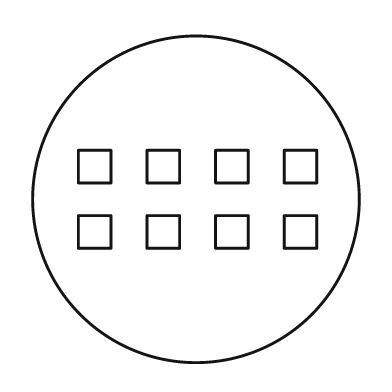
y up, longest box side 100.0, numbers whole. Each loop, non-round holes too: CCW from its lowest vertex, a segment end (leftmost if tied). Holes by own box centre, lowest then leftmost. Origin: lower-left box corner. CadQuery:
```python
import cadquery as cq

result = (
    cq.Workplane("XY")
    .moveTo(50.0, 50.0)
    .circle(50.0)
    .moveTo(14.0, 35.0)
    .lineTo(24.0, 35.0)
    .lineTo(24.0, 45.0)
    .lineTo(14.0, 45.0)
    .close()
    .moveTo(35.0, 35.0)
    .lineTo(45.0, 35.0)
    .lineTo(45.0, 45.0)
    .lineTo(35.0, 45.0)
    .close()
    .moveTo(56.0, 35.0)
    .lineTo(66.0, 35.0)
    .lineTo(66.0, 45.0)
    .lineTo(56.0, 45.0)
    .close()
    .moveTo(77.0, 35.0)
    .lineTo(87.0, 35.0)
    .lineTo(87.0, 45.0)
    .lineTo(77.0, 45.0)
    .close()
    .moveTo(14.0, 55.0)
    .lineTo(24.0, 55.0)
    .lineTo(24.0, 65.0)
    .lineTo(14.0, 65.0)
    .close()
    .moveTo(35.0, 55.0)
    .lineTo(45.0, 55.0)
    .lineTo(45.0, 65.0)
    .lineTo(35.0, 65.0)
    .close()
    .moveTo(56.0, 55.0)
    .lineTo(66.0, 55.0)
    .lineTo(66.0, 65.0)
    .lineTo(56.0, 65.0)
    .close()
    .moveTo(77.0, 55.0)
    .lineTo(87.0, 55.0)
    .lineTo(87.0, 65.0)
    .lineTo(77.0, 65.0)
    .close()
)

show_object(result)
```